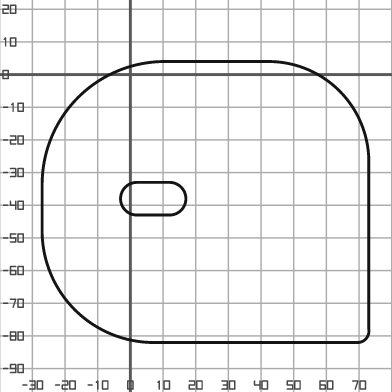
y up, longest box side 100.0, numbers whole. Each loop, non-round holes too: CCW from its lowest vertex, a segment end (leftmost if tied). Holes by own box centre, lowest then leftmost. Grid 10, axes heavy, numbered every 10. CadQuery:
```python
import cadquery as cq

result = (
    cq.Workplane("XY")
    .moveTo(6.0, -82.0)
    .lineTo(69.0, -82.0)
    .threePointArc((72.0, -81.0), (73.0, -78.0))
    .lineTo(73.0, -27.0)
    .threePointArc((64.0, -5.0), (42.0, 4.0))
    .lineTo(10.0, 4.0)
    .threePointArc((-16.0, -7.0), (-27.0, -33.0))
    .lineTo(-27.0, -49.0)
    .threePointArc((-17.0, -72.0), (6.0, -82.0))
    .close()
    .moveTo(2.0, -43.0)
    .lineTo(12.0, -43.0)
    .threePointArc((17.0, -38.0), (12.0, -33.0))
    .lineTo(2.0, -33.0)
    .threePointArc((-3.0, -38.0), (2.0, -43.0))
    .close()
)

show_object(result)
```